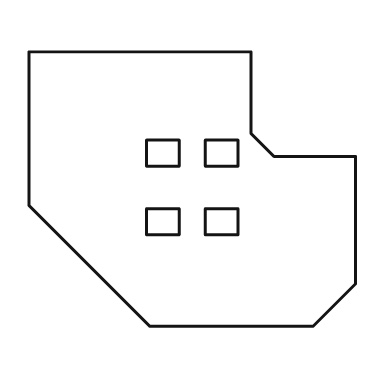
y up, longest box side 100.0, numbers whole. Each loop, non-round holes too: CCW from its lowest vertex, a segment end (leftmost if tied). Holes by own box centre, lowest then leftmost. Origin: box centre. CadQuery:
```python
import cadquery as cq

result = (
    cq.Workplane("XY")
    .moveTo(-13.0, -42.0)
    .lineTo(37.0, -42.0)
    .lineTo(50.0, -29.0)
    .lineTo(50.0, 10.0)
    .lineTo(25.0, 10.0)
    .lineTo(18.0, 17.0)
    .lineTo(18.0, 42.0)
    .lineTo(-50.0, 42.0)
    .lineTo(-50.0, -5.0)
    .close()
    .moveTo(-14.0, -14.0)
    .lineTo(-4.0, -14.0)
    .lineTo(-4.0, -6.0)
    .lineTo(-14.0, -6.0)
    .close()
    .moveTo(4.0, -14.0)
    .lineTo(14.0, -14.0)
    .lineTo(14.0, -6.0)
    .lineTo(4.0, -6.0)
    .close()
    .moveTo(-14.0, 7.0)
    .lineTo(-4.0, 7.0)
    .lineTo(-4.0, 15.0)
    .lineTo(-14.0, 15.0)
    .close()
    .moveTo(4.0, 7.0)
    .lineTo(14.0, 7.0)
    .lineTo(14.0, 15.0)
    .lineTo(4.0, 15.0)
    .close()
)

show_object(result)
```